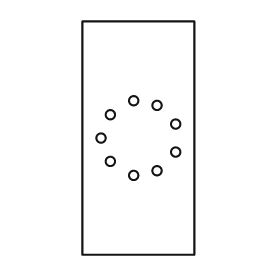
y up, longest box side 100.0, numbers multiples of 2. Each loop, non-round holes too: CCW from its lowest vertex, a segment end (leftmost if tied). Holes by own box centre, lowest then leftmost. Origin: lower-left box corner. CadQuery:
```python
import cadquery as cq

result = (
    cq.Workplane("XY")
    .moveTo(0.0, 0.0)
    .lineTo(48.0, 0.0)
    .lineTo(48.0, 100.0)
    .lineTo(0.0, 100.0)
    .close()
    .moveTo(22.0, 34.0)
    .circle(2.0)
    .moveTo(32.0, 36.0)
    .circle(2.0)
    .moveTo(12.0, 40.0)
    .circle(2.0)
    .moveTo(40.0, 44.0)
    .circle(2.0)
    .moveTo(8.0, 50.0)
    .circle(2.0)
    .moveTo(40.0, 56.0)
    .circle(2.0)
    .moveTo(12.0, 60.0)
    .circle(2.0)
    .moveTo(32.0, 64.0)
    .circle(2.0)
    .moveTo(22.0, 66.0)
    .circle(2.0)
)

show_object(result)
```